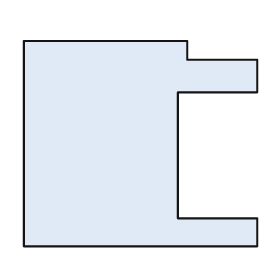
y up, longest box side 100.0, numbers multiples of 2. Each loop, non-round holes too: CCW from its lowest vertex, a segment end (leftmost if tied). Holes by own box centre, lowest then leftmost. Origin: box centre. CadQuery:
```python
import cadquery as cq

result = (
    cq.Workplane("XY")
    .moveTo(-50.0, -44.0)
    .lineTo(50.0, -44.0)
    .lineTo(50.0, -32.0)
    .lineTo(16.0, -32.0)
    .lineTo(16.0, 22.0)
    .lineTo(50.0, 22.0)
    .lineTo(50.0, 36.0)
    .lineTo(20.0, 36.0)
    .lineTo(20.0, 44.0)
    .lineTo(-50.0, 44.0)
    .close()
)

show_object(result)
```